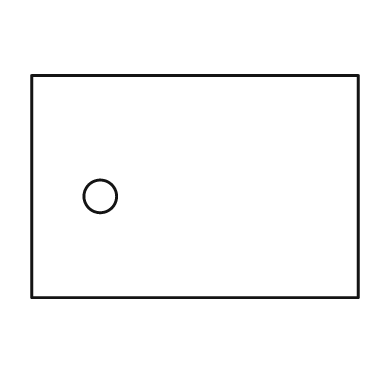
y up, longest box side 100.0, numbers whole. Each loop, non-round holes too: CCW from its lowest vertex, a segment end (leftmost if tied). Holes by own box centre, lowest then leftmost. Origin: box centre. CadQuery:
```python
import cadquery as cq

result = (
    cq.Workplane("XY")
    .moveTo(-50.0, -34.0)
    .lineTo(50.0, -34.0)
    .lineTo(50.0, 34.0)
    .lineTo(-50.0, 34.0)
    .close()
    .moveTo(-29.0, -3.0)
    .circle(5.0)
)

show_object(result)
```